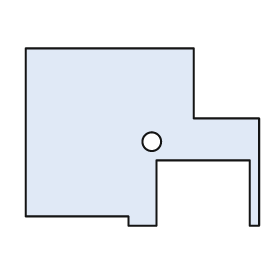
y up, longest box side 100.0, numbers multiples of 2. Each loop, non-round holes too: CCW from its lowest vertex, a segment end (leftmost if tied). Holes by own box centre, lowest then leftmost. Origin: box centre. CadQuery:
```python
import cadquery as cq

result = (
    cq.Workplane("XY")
    .moveTo(-6.0, -38.0)
    .lineTo(6.0, -38.0)
    .lineTo(6.0, -10.0)
    .lineTo(46.0, -10.0)
    .lineTo(46.0, -38.0)
    .lineTo(50.0, -38.0)
    .lineTo(50.0, 8.0)
    .lineTo(22.0, 8.0)
    .lineTo(22.0, 38.0)
    .lineTo(-50.0, 38.0)
    .lineTo(-50.0, -34.0)
    .lineTo(-6.0, -34.0)
    .close()
    .moveTo(4.0, -2.0)
    .circle(4.0)
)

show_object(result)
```